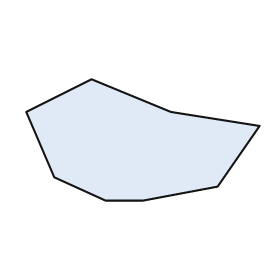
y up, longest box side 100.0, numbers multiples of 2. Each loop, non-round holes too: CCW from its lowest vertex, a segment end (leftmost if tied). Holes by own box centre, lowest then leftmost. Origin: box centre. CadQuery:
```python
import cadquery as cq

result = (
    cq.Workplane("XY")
    .moveTo(-16.0, -26.0)
    .lineTo(0.0, -26.0)
    .lineTo(32.0, -20.0)
    .lineTo(50.0, 6.0)
    .lineTo(12.0, 12.0)
    .lineTo(-22.0, 26.0)
    .lineTo(-50.0, 12.0)
    .lineTo(-38.0, -16.0)
    .close()
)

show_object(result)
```